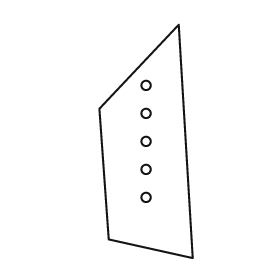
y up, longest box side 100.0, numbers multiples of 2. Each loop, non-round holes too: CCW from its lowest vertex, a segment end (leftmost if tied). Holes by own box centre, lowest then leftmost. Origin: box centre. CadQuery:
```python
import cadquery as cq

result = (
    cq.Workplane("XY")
    .moveTo(20.0, -50.0)
    .lineTo(14.0, 50.0)
    .lineTo(-20.0, 14.0)
    .lineTo(-16.0, -42.0)
    .close()
    .moveTo(0.0, -24.0)
    .circle(2.0)
    .moveTo(0.0, -12.0)
    .circle(2.0)
    .moveTo(0.0, 0.0)
    .circle(2.0)
    .moveTo(0.0, 12.0)
    .circle(2.0)
    .moveTo(0.0, 24.0)
    .circle(2.0)
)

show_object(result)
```